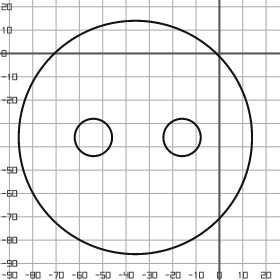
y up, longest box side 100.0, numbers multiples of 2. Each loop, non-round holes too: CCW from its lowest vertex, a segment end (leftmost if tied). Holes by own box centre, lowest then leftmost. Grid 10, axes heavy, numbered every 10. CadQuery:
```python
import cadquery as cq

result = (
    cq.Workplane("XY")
    .moveTo(-36.0, -36.0)
    .circle(50.0)
    .moveTo(-54.0, -36.0)
    .circle(8.0)
    .moveTo(-16.0, -36.0)
    .circle(8.0)
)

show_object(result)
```